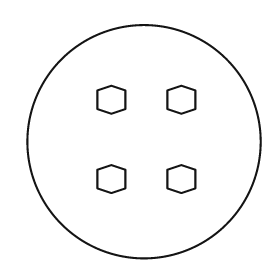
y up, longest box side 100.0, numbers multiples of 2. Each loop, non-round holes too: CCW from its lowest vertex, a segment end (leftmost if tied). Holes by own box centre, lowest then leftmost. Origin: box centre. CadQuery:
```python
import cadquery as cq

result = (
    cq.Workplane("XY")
    .moveTo(0.0, 0.0)
    .circle(50.0)
    .moveTo(-14.0, -22.0)
    .lineTo(-8.0, -20.0)
    .lineTo(-8.0, -12.0)
    .lineTo(-14.0, -10.0)
    .lineTo(-20.0, -12.0)
    .lineTo(-20.0, -20.0)
    .close()
    .moveTo(16.0, -22.0)
    .lineTo(22.0, -20.0)
    .lineTo(22.0, -12.0)
    .lineTo(16.0, -10.0)
    .lineTo(10.0, -12.0)
    .lineTo(10.0, -20.0)
    .close()
    .moveTo(-14.0, 12.0)
    .lineTo(-8.0, 14.0)
    .lineTo(-8.0, 22.0)
    .lineTo(-14.0, 24.0)
    .lineTo(-20.0, 22.0)
    .lineTo(-20.0, 14.0)
    .close()
    .moveTo(16.0, 12.0)
    .lineTo(22.0, 14.0)
    .lineTo(22.0, 22.0)
    .lineTo(16.0, 24.0)
    .lineTo(10.0, 22.0)
    .lineTo(10.0, 14.0)
    .close()
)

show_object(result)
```